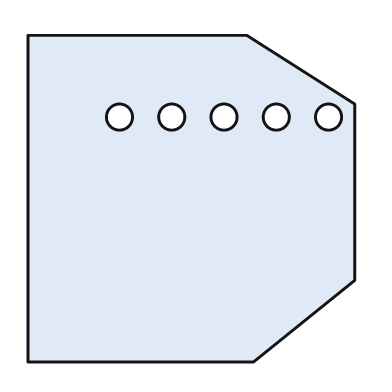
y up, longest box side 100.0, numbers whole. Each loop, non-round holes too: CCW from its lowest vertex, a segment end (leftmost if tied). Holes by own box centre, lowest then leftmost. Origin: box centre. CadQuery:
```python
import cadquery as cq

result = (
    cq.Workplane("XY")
    .moveTo(-50.0, -50.0)
    .lineTo(19.0, -50.0)
    .lineTo(50.0, -25.0)
    .lineTo(50.0, 29.0)
    .lineTo(17.0, 50.0)
    .lineTo(-50.0, 50.0)
    .close()
    .moveTo(-22.0, 25.0)
    .circle(4.0)
    .moveTo(-6.0, 25.0)
    .circle(4.0)
    .moveTo(10.0, 25.0)
    .circle(4.0)
    .moveTo(26.0, 25.0)
    .circle(4.0)
    .moveTo(42.0, 25.0)
    .circle(4.0)
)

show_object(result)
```